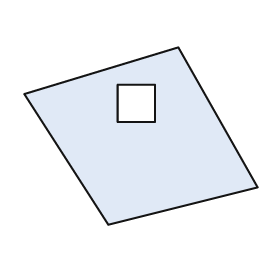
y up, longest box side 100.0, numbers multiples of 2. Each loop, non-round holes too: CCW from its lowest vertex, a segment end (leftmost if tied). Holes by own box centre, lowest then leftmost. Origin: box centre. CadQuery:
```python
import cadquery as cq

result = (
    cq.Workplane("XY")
    .moveTo(-14.0, -38.0)
    .lineTo(50.0, -22.0)
    .lineTo(16.0, 38.0)
    .lineTo(-50.0, 18.0)
    .close()
    .moveTo(-10.0, 6.0)
    .lineTo(6.0, 6.0)
    .lineTo(6.0, 22.0)
    .lineTo(-10.0, 22.0)
    .close()
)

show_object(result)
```